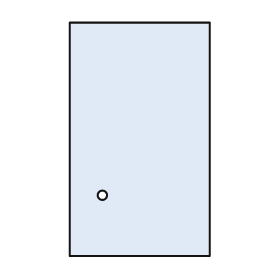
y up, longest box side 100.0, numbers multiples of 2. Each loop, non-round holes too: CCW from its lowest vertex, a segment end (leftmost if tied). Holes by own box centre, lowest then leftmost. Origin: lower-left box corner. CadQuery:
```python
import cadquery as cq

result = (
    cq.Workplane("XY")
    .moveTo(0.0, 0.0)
    .lineTo(60.0, 0.0)
    .lineTo(60.0, 100.0)
    .lineTo(0.0, 100.0)
    .close()
    .moveTo(14.0, 26.0)
    .circle(2.0)
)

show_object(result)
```